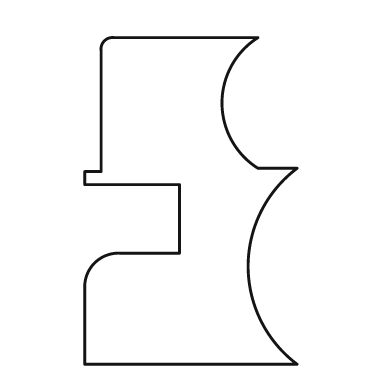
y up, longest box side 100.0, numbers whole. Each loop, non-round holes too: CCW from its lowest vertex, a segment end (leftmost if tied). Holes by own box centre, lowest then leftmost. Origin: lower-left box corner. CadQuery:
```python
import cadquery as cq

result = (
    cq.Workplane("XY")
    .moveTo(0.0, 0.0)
    .lineTo(65.0, 0.0)
    .threePointArc((50.0, 30.0), (65.0, 60.0))
    .lineTo(53.0, 60.0)
    .threePointArc((42.0, 80.0), (53.0, 100.0))
    .lineTo(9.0, 100.0)
    .threePointArc((6.0, 99.0), (5.0, 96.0))
    .lineTo(5.0, 59.0)
    .lineTo(0.0, 59.0)
    .lineTo(0.0, 55.0)
    .lineTo(29.0, 55.0)
    .lineTo(29.0, 34.0)
    .lineTo(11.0, 34.0)
    .threePointArc((3.0, 31.0), (0.0, 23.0))
    .close()
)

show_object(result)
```